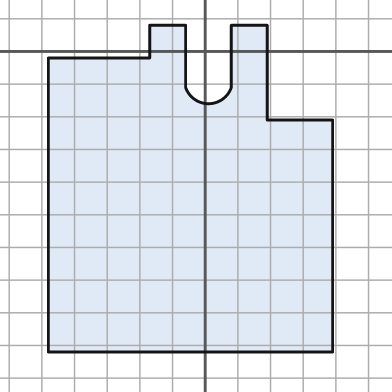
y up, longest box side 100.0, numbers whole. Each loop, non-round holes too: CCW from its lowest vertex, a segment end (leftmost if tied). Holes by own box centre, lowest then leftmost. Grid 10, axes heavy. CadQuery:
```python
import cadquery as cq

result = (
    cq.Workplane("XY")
    .moveTo(-48.0, -92.0)
    .lineTo(39.0, -92.0)
    .lineTo(39.0, -21.0)
    .lineTo(19.0, -21.0)
    .lineTo(19.0, 8.0)
    .lineTo(8.0, 8.0)
    .lineTo(8.0, -11.0)
    .threePointArc((1.0, -16.0), (-6.0, -11.0))
    .lineTo(-6.0, 8.0)
    .lineTo(-17.0, 8.0)
    .lineTo(-17.0, -2.0)
    .lineTo(-48.0, -2.0)
    .close()
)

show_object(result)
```